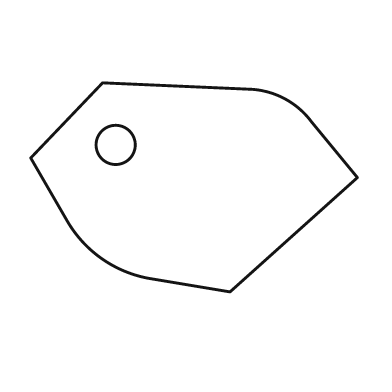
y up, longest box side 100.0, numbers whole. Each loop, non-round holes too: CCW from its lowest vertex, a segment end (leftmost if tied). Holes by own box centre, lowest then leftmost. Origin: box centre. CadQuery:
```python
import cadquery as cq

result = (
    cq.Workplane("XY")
    .moveTo(11.0, -32.0)
    .lineTo(50.0, 3.0)
    .lineTo(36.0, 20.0)
    .threePointArc((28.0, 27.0), (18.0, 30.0))
    .lineTo(-28.0, 32.0)
    .lineTo(-50.0, 9.0)
    .lineTo(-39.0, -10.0)
    .threePointArc((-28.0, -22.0), (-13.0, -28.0))
    .close()
    .moveTo(-24.0, 13.0)
    .circle(6.0)
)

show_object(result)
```